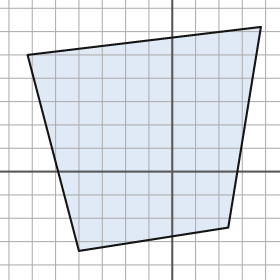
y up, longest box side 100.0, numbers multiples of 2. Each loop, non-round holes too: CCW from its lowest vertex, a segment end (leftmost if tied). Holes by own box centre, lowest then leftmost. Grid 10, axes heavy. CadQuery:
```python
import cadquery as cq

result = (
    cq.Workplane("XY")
    .moveTo(-40.0, -34.0)
    .lineTo(24.0, -24.0)
    .lineTo(38.0, 62.0)
    .lineTo(-62.0, 50.0)
    .close()
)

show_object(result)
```